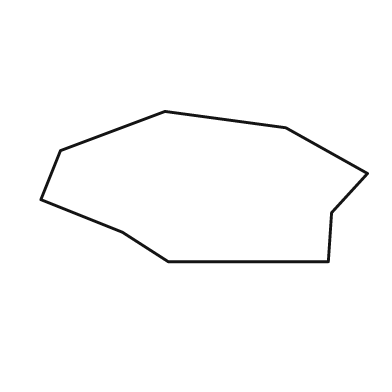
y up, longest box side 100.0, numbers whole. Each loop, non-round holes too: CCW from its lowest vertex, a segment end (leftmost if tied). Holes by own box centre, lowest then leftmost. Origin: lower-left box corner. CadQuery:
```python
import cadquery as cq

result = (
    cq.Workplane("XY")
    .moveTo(39.0, 0.0)
    .lineTo(88.0, 0.0)
    .lineTo(89.0, 15.0)
    .lineTo(100.0, 27.0)
    .lineTo(75.0, 41.0)
    .lineTo(38.0, 46.0)
    .lineTo(6.0, 34.0)
    .lineTo(0.0, 19.0)
    .lineTo(25.0, 9.0)
    .close()
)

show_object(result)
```